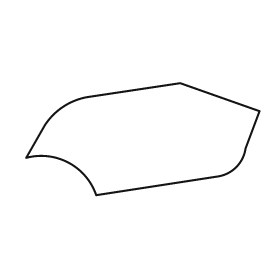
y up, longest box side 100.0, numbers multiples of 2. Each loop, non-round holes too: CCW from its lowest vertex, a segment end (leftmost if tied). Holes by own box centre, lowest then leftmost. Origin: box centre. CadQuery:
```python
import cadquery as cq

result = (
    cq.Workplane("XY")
    .moveTo(-20.0, -24.0)
    .lineTo(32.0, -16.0)
    .threePointArc((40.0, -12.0), (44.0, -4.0))
    .lineTo(50.0, 12.0)
    .lineTo(16.0, 24.0)
    .lineTo(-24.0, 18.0)
    .threePointArc((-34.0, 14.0), (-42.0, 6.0))
    .lineTo(-50.0, -8.0)
    .threePointArc((-32.0, -10.0), (-20.0, -24.0))
    .close()
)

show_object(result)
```